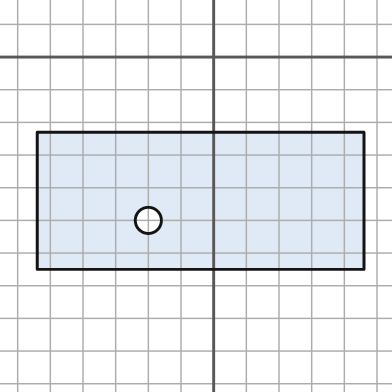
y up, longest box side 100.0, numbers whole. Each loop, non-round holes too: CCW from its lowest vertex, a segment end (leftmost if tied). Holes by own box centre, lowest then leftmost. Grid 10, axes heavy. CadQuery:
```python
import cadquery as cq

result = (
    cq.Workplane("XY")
    .moveTo(-54.0, -65.0)
    .lineTo(46.0, -65.0)
    .lineTo(46.0, -23.0)
    .lineTo(-54.0, -23.0)
    .close()
    .moveTo(-20.0, -50.0)
    .circle(4.0)
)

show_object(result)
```